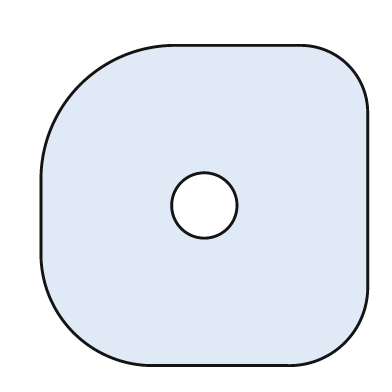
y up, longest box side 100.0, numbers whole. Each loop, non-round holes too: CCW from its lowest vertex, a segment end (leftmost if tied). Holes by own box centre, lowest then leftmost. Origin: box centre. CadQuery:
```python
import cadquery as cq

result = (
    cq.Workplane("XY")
    .moveTo(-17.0, -49.0)
    .lineTo(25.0, -49.0)
    .threePointArc((43.0, -42.0), (50.0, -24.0))
    .lineTo(50.0, 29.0)
    .threePointArc((44.0, 43.0), (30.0, 49.0))
    .lineTo(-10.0, 49.0)
    .threePointArc((-38.0, 37.0), (-50.0, 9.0))
    .lineTo(-50.0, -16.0)
    .threePointArc((-40.0, -39.0), (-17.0, -49.0))
    .close()
    .moveTo(0.0, 0.0)
    .circle(10.0)
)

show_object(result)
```